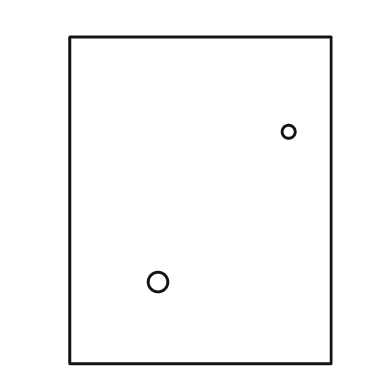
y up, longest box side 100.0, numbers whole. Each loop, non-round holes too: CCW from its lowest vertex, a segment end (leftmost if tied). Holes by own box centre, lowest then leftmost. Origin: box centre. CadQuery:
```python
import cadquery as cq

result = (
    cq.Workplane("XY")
    .moveTo(-40.0, -50.0)
    .lineTo(40.0, -50.0)
    .lineTo(40.0, 50.0)
    .lineTo(-40.0, 50.0)
    .close()
    .moveTo(-13.0, -25.0)
    .circle(3.0)
    .moveTo(27.0, 21.0)
    .circle(2.0)
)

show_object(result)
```